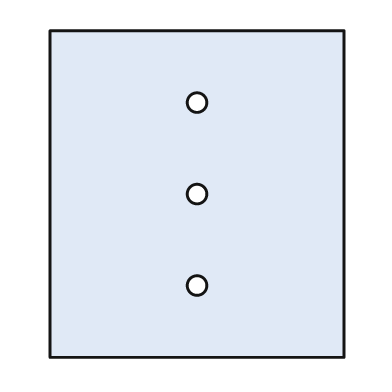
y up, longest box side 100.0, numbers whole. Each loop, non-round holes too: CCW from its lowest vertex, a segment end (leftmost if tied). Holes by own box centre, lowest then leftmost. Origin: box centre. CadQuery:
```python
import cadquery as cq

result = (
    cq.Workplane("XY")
    .moveTo(-45.0, -50.0)
    .lineTo(45.0, -50.0)
    .lineTo(45.0, 50.0)
    .lineTo(-45.0, 50.0)
    .close()
    .moveTo(0.0, -28.0)
    .circle(3.0)
    .moveTo(0.0, 0.0)
    .circle(3.0)
    .moveTo(0.0, 28.0)
    .circle(3.0)
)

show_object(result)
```